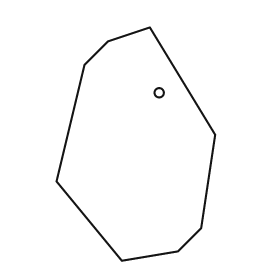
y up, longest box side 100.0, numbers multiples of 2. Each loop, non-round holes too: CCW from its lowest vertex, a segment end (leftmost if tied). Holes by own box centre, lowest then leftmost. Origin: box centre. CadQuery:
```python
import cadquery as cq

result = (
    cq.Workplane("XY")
    .moveTo(-6.0, -50.0)
    .lineTo(18.0, -46.0)
    .lineTo(28.0, -36.0)
    .lineTo(34.0, 4.0)
    .lineTo(6.0, 50.0)
    .lineTo(-12.0, 44.0)
    .lineTo(-22.0, 34.0)
    .lineTo(-34.0, -16.0)
    .close()
    .moveTo(10.0, 22.0)
    .circle(2.0)
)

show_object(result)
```